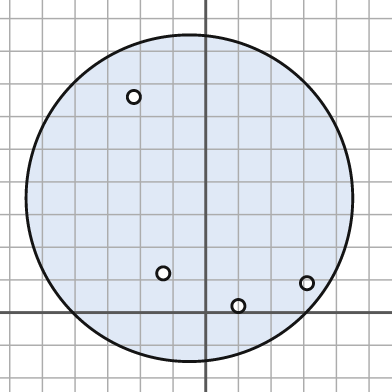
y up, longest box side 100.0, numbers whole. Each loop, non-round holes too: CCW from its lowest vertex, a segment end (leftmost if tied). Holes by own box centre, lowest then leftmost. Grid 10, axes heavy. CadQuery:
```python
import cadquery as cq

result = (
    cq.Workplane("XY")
    .moveTo(-5.0, 35.0)
    .circle(50.0)
    .moveTo(10.0, 2.0)
    .circle(2.0)
    .moveTo(31.0, 9.0)
    .circle(2.0)
    .moveTo(-13.0, 12.0)
    .circle(2.0)
    .moveTo(-22.0, 66.0)
    .circle(2.0)
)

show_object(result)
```